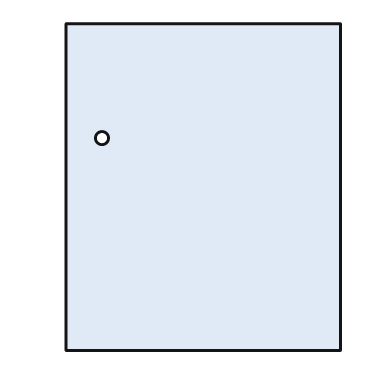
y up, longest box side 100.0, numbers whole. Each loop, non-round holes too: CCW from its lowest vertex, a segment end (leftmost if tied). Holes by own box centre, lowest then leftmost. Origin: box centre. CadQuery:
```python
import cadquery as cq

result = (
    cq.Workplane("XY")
    .moveTo(-42.0, -50.0)
    .lineTo(42.0, -50.0)
    .lineTo(42.0, 50.0)
    .lineTo(-42.0, 50.0)
    .close()
    .moveTo(-31.0, 15.0)
    .circle(2.0)
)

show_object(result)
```